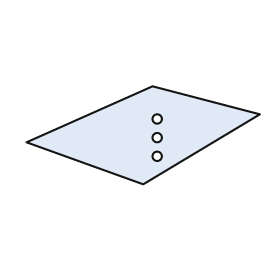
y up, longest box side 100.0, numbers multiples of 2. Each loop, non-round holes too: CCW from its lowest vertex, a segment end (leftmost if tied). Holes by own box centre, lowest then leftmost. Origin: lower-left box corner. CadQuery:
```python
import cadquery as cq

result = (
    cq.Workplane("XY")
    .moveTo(50.0, 0.0)
    .lineTo(100.0, 30.0)
    .lineTo(54.0, 42.0)
    .lineTo(0.0, 18.0)
    .close()
    .moveTo(56.0, 12.0)
    .circle(2.0)
    .moveTo(56.0, 20.0)
    .circle(2.0)
    .moveTo(56.0, 28.0)
    .circle(2.0)
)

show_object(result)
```